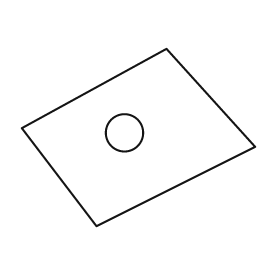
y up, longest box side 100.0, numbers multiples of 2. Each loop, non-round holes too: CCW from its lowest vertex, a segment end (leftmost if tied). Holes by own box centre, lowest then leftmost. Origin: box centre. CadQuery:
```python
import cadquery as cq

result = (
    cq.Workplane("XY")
    .moveTo(-18.0, -38.0)
    .lineTo(50.0, -4.0)
    .lineTo(12.0, 38.0)
    .lineTo(-50.0, 4.0)
    .close()
    .moveTo(-6.0, 2.0)
    .circle(8.0)
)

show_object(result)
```